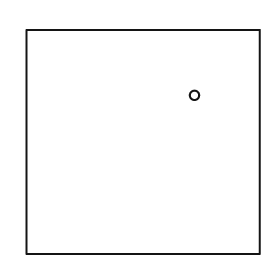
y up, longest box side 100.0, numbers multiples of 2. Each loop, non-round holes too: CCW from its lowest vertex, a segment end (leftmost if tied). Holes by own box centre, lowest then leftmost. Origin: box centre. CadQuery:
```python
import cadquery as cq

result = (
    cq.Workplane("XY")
    .moveTo(-50.0, -48.0)
    .lineTo(50.0, -48.0)
    .lineTo(50.0, 48.0)
    .lineTo(-50.0, 48.0)
    .close()
    .moveTo(22.0, 20.0)
    .circle(2.0)
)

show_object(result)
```